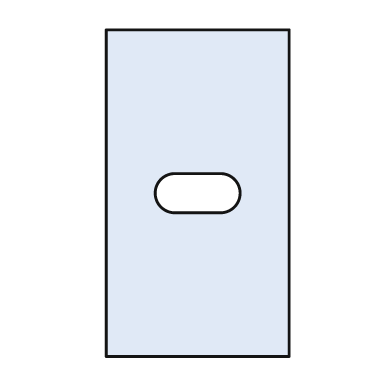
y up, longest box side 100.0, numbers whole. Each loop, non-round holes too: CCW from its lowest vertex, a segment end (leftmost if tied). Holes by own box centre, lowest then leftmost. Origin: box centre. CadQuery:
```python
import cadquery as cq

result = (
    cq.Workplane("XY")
    .moveTo(-28.0, -50.0)
    .lineTo(28.0, -50.0)
    .lineTo(28.0, 50.0)
    .lineTo(-28.0, 50.0)
    .close()
    .moveTo(-7.0, -6.0)
    .lineTo(7.0, -6.0)
    .threePointArc((13.0, 0.0), (7.0, 6.0))
    .lineTo(-7.0, 6.0)
    .threePointArc((-13.0, 0.0), (-7.0, -6.0))
    .close()
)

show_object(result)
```